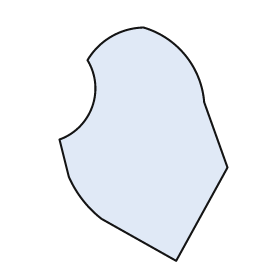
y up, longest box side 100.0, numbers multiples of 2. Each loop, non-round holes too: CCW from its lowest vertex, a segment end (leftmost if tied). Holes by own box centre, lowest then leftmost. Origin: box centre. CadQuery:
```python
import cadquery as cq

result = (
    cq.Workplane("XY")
    .moveTo(14.0, -50.0)
    .lineTo(36.0, -10.0)
    .lineTo(26.0, 18.0)
    .threePointArc((18.0, 38.0), (0.0, 50.0))
    .threePointArc((-14.0, 46.0), (-24.0, 36.0))
    .threePointArc((-22.0, 16.0), (-36.0, 2.0))
    .lineTo(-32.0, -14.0)
    .threePointArc((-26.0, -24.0), (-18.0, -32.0))
    .close()
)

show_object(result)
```